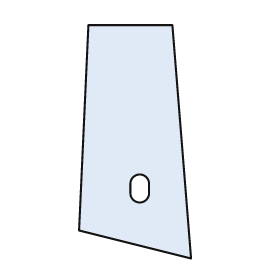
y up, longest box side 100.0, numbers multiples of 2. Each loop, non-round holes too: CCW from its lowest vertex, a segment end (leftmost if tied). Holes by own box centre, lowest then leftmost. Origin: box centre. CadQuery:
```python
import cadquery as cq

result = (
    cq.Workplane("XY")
    .moveTo(24.0, -50.0)
    .lineTo(16.0, 50.0)
    .lineTo(-20.0, 50.0)
    .lineTo(-24.0, -38.0)
    .close()
    .moveTo(-2.0, -22.0)
    .threePointArc((2.0, -26.0), (6.0, -22.0))
    .lineTo(6.0, -18.0)
    .threePointArc((2.0, -14.0), (-2.0, -18.0))
    .close()
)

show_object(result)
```